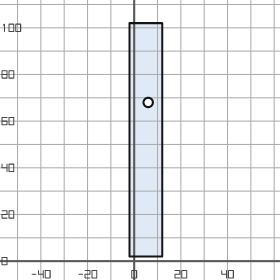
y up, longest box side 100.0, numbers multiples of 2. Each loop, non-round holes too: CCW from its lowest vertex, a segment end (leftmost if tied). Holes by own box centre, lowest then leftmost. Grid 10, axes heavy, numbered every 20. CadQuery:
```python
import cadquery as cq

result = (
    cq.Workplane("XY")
    .moveTo(-2.0, 2.0)
    .lineTo(12.0, 2.0)
    .lineTo(12.0, 102.0)
    .lineTo(-2.0, 102.0)
    .close()
    .moveTo(6.0, 68.0)
    .circle(2.0)
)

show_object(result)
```